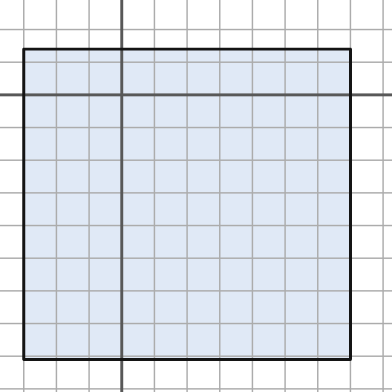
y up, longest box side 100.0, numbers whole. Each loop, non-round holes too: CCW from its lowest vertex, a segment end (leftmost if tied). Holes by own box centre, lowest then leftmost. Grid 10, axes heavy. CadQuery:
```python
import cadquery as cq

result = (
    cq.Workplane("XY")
    .moveTo(-30.0, -81.0)
    .lineTo(70.0, -81.0)
    .lineTo(70.0, 14.0)
    .lineTo(-30.0, 14.0)
    .close()
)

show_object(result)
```